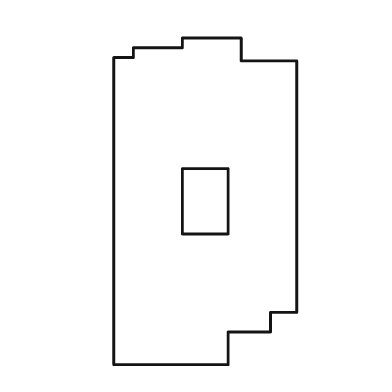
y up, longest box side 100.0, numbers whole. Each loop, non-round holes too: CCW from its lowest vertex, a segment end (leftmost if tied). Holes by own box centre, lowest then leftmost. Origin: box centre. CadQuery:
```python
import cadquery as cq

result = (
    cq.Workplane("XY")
    .moveTo(-28.0, -50.0)
    .lineTo(7.0, -50.0)
    .lineTo(7.0, -40.0)
    .lineTo(20.0, -40.0)
    .lineTo(20.0, -34.0)
    .lineTo(28.0, -34.0)
    .lineTo(28.0, 43.0)
    .lineTo(11.0, 43.0)
    .lineTo(11.0, 50.0)
    .lineTo(-7.0, 50.0)
    .lineTo(-7.0, 47.0)
    .lineTo(-22.0, 47.0)
    .lineTo(-22.0, 44.0)
    .lineTo(-28.0, 44.0)
    .close()
    .moveTo(-7.0, -10.0)
    .lineTo(7.0, -10.0)
    .lineTo(7.0, 10.0)
    .lineTo(-7.0, 10.0)
    .close()
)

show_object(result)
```